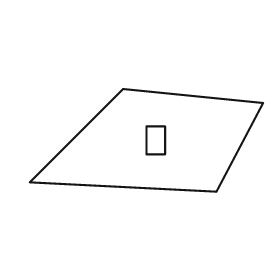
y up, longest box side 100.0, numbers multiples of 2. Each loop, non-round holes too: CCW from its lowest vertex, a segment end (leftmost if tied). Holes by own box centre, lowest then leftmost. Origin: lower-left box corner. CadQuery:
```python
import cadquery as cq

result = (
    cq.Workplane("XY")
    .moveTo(80.0, 0.0)
    .lineTo(100.0, 38.0)
    .lineTo(40.0, 44.0)
    .lineTo(0.0, 4.0)
    .close()
    .moveTo(50.0, 16.0)
    .lineTo(58.0, 16.0)
    .lineTo(58.0, 28.0)
    .lineTo(50.0, 28.0)
    .close()
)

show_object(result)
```